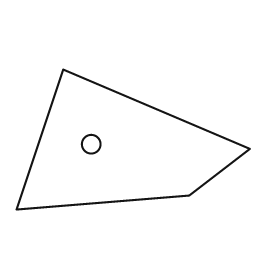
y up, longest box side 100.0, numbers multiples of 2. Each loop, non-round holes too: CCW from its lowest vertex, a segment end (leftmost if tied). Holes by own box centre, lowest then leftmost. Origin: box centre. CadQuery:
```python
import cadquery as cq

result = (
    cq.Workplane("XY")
    .moveTo(-50.0, -30.0)
    .lineTo(24.0, -24.0)
    .lineTo(50.0, -4.0)
    .lineTo(-30.0, 30.0)
    .close()
    .moveTo(-18.0, -2.0)
    .circle(4.0)
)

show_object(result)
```